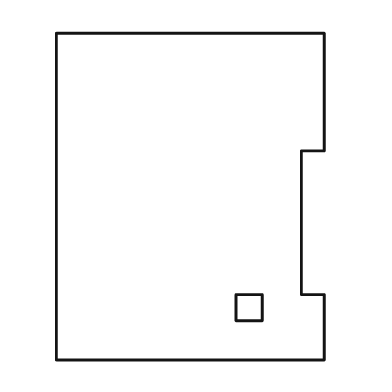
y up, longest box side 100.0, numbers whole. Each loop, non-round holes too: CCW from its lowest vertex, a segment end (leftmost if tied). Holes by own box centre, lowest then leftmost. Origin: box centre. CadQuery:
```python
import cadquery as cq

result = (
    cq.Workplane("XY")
    .moveTo(-41.0, -50.0)
    .lineTo(41.0, -50.0)
    .lineTo(41.0, -30.0)
    .lineTo(34.0, -30.0)
    .lineTo(34.0, 14.0)
    .lineTo(41.0, 14.0)
    .lineTo(41.0, 50.0)
    .lineTo(-41.0, 50.0)
    .close()
    .moveTo(14.0, -38.0)
    .lineTo(22.0, -38.0)
    .lineTo(22.0, -30.0)
    .lineTo(14.0, -30.0)
    .close()
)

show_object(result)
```